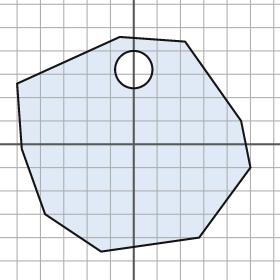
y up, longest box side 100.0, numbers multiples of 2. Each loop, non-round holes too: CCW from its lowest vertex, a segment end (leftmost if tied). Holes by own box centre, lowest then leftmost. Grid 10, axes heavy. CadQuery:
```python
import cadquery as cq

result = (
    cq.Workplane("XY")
    .moveTo(-14.0, -46.0)
    .lineTo(28.0, -40.0)
    .lineTo(50.0, -10.0)
    .lineTo(46.0, 10.0)
    .lineTo(22.0, 44.0)
    .lineTo(-6.0, 46.0)
    .lineTo(-50.0, 26.0)
    .lineTo(-48.0, -2.0)
    .lineTo(-38.0, -30.0)
    .close()
    .moveTo(0.0, 32.0)
    .circle(8.0)
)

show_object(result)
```